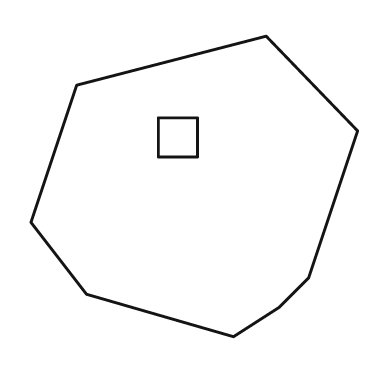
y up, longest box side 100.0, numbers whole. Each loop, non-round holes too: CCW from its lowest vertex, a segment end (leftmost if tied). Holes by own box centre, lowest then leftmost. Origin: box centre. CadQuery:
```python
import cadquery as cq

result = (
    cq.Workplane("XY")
    .moveTo(12.0, -46.0)
    .lineTo(26.0, -37.0)
    .lineTo(35.0, -28.0)
    .lineTo(50.0, 17.0)
    .lineTo(22.0, 46.0)
    .lineTo(-36.0, 31.0)
    .lineTo(-50.0, -11.0)
    .lineTo(-33.0, -33.0)
    .close()
    .moveTo(-11.0, 9.0)
    .lineTo(1.0, 9.0)
    .lineTo(1.0, 21.0)
    .lineTo(-11.0, 21.0)
    .close()
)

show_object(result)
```